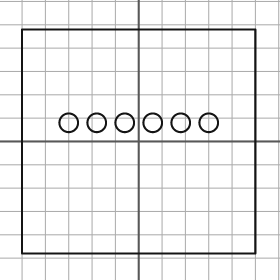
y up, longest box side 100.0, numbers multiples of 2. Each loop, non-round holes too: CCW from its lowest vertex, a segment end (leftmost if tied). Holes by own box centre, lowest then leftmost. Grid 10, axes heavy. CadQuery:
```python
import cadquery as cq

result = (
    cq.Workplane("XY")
    .moveTo(-50.0, -48.0)
    .lineTo(50.0, -48.0)
    .lineTo(50.0, 48.0)
    .lineTo(-50.0, 48.0)
    .close()
    .moveTo(-30.0, 8.0)
    .circle(4.0)
    .moveTo(-18.0, 8.0)
    .circle(4.0)
    .moveTo(-6.0, 8.0)
    .circle(4.0)
    .moveTo(6.0, 8.0)
    .circle(4.0)
    .moveTo(18.0, 8.0)
    .circle(4.0)
    .moveTo(30.0, 8.0)
    .circle(4.0)
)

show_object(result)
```